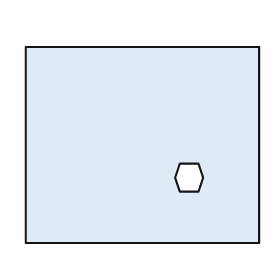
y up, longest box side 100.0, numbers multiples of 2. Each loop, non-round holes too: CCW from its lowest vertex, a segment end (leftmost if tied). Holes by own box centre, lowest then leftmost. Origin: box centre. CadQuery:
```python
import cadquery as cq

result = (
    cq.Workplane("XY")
    .moveTo(-50.0, -42.0)
    .lineTo(50.0, -42.0)
    .lineTo(50.0, 42.0)
    .lineTo(-50.0, 42.0)
    .close()
    .moveTo(16.0, -20.0)
    .lineTo(24.0, -20.0)
    .lineTo(26.0, -14.0)
    .lineTo(24.0, -8.0)
    .lineTo(16.0, -8.0)
    .lineTo(14.0, -14.0)
    .close()
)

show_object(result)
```